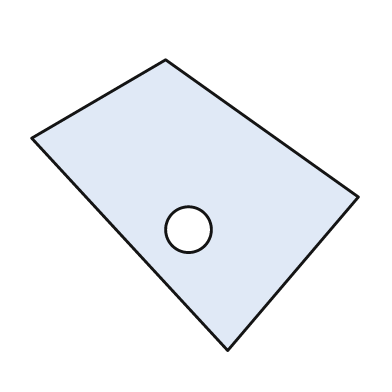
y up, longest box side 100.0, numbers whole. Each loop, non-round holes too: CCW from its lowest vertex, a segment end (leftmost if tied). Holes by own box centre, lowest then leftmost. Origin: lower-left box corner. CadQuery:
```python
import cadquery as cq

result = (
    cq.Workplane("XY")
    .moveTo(60.0, 0.0)
    .lineTo(100.0, 47.0)
    .lineTo(41.0, 89.0)
    .lineTo(0.0, 65.0)
    .close()
    .moveTo(48.0, 37.0)
    .circle(7.0)
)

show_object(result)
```